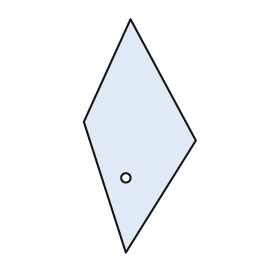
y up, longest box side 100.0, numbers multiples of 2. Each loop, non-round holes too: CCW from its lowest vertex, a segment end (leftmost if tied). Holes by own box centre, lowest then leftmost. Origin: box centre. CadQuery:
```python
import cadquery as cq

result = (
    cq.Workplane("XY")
    .moveTo(-6.0, -50.0)
    .lineTo(24.0, -2.0)
    .lineTo(-4.0, 50.0)
    .lineTo(-24.0, 6.0)
    .close()
    .moveTo(-6.0, -18.0)
    .circle(2.0)
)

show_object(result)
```